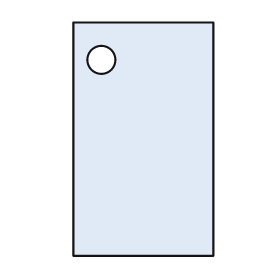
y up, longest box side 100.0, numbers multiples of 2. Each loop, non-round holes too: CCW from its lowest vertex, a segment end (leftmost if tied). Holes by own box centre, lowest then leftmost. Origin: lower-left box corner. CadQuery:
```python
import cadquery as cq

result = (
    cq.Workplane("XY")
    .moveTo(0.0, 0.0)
    .lineTo(60.0, 0.0)
    .lineTo(60.0, 100.0)
    .lineTo(0.0, 100.0)
    .close()
    .moveTo(12.0, 84.0)
    .circle(6.0)
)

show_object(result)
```